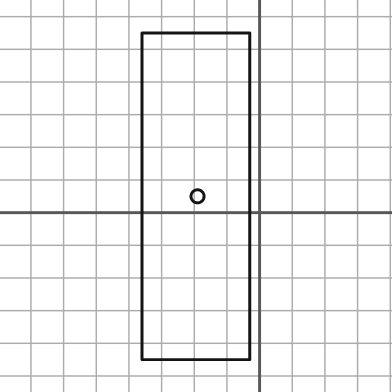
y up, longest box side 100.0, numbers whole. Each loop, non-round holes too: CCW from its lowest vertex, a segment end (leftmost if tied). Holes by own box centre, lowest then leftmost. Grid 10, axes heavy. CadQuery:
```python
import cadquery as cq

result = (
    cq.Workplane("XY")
    .moveTo(-36.0, -45.0)
    .lineTo(-3.0, -45.0)
    .lineTo(-3.0, 55.0)
    .lineTo(-36.0, 55.0)
    .close()
    .moveTo(-19.0, 5.0)
    .circle(2.0)
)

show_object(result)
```